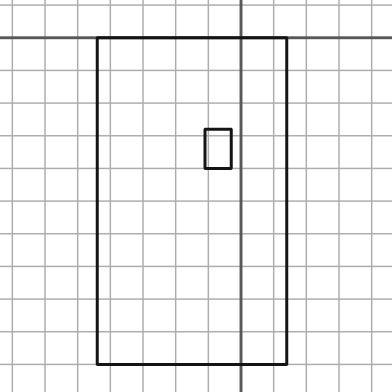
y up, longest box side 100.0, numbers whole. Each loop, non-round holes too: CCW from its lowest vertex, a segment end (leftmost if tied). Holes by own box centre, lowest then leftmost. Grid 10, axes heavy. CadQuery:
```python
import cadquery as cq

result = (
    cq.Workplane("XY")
    .moveTo(-44.0, -100.0)
    .lineTo(14.0, -100.0)
    .lineTo(14.0, 0.0)
    .lineTo(-44.0, 0.0)
    .close()
    .moveTo(-11.0, -40.0)
    .lineTo(-3.0, -40.0)
    .lineTo(-3.0, -28.0)
    .lineTo(-11.0, -28.0)
    .close()
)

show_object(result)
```